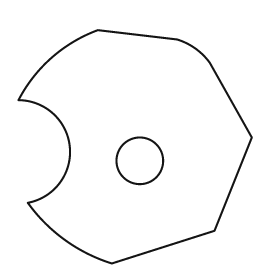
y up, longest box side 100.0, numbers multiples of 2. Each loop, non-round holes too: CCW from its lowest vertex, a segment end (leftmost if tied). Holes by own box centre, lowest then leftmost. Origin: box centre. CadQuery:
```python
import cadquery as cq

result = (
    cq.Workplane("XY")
    .moveTo(-10.0, -50.0)
    .lineTo(34.0, -36.0)
    .lineTo(50.0, 4.0)
    .lineTo(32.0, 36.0)
    .threePointArc((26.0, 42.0), (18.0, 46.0))
    .lineTo(-16.0, 50.0)
    .threePointArc((-36.0, 38.0), (-50.0, 20.0))
    .threePointArc((-28.0, 0.0), (-46.0, -24.0))
    .threePointArc((-30.0, -40.0), (-10.0, -50.0))
    .close()
    .moveTo(2.0, -6.0)
    .circle(10.0)
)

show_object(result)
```